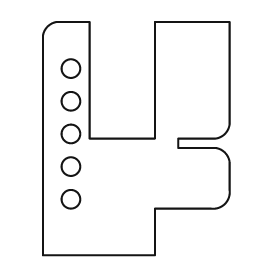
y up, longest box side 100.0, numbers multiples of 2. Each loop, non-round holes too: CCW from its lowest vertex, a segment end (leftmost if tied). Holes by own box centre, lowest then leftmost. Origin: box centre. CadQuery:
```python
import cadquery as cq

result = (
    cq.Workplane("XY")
    .moveTo(-40.0, -50.0)
    .lineTo(8.0, -50.0)
    .lineTo(8.0, -30.0)
    .lineTo(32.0, -30.0)
    .threePointArc((38.0, -28.0), (40.0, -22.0))
    .lineTo(40.0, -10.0)
    .threePointArc((38.0, -6.0), (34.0, -4.0))
    .lineTo(18.0, -4.0)
    .lineTo(18.0, 0.0)
    .lineTo(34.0, 0.0)
    .threePointArc((38.0, 2.0), (40.0, 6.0))
    .lineTo(40.0, 50.0)
    .lineTo(8.0, 50.0)
    .lineTo(8.0, 0.0)
    .lineTo(-20.0, 0.0)
    .lineTo(-20.0, 50.0)
    .lineTo(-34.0, 50.0)
    .threePointArc((-38.0, 48.0), (-40.0, 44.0))
    .close()
    .moveTo(-28.0, -26.0)
    .circle(4.0)
    .moveTo(-28.0, -12.0)
    .circle(4.0)
    .moveTo(-28.0, 2.0)
    .circle(4.0)
    .moveTo(-28.0, 16.0)
    .circle(4.0)
    .moveTo(-28.0, 30.0)
    .circle(4.0)
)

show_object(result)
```